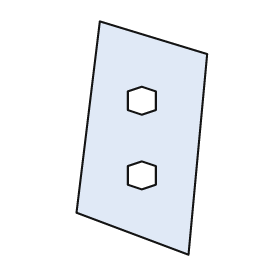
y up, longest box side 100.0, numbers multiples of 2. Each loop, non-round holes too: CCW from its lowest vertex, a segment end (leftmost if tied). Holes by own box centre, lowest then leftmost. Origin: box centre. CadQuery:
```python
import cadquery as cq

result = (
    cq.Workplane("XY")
    .moveTo(20.0, -50.0)
    .lineTo(28.0, 36.0)
    .lineTo(-18.0, 50.0)
    .lineTo(-28.0, -32.0)
    .close()
    .moveTo(0.0, -22.0)
    .lineTo(6.0, -20.0)
    .lineTo(6.0, -12.0)
    .lineTo(0.0, -10.0)
    .lineTo(-6.0, -12.0)
    .lineTo(-6.0, -20.0)
    .close()
    .moveTo(0.0, 10.0)
    .lineTo(6.0, 12.0)
    .lineTo(6.0, 20.0)
    .lineTo(0.0, 22.0)
    .lineTo(-6.0, 20.0)
    .lineTo(-6.0, 12.0)
    .close()
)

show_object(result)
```